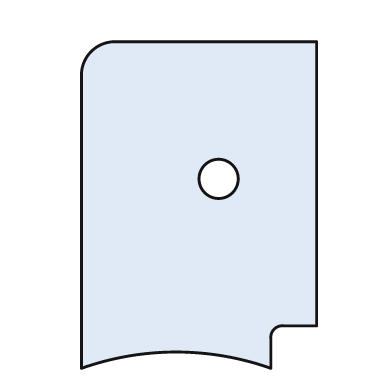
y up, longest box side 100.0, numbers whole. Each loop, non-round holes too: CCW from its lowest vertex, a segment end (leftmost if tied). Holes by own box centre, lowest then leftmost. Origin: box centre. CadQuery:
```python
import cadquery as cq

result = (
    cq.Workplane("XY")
    .moveTo(-36.0, -50.0)
    .threePointArc((-7.0, -45.0), (22.0, -50.0))
    .lineTo(22.0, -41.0)
    .threePointArc((23.0, -38.0), (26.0, -37.0))
    .lineTo(36.0, -37.0)
    .lineTo(36.0, 50.0)
    .lineTo(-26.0, 50.0)
    .threePointArc((-33.0, 47.0), (-36.0, 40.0))
    .close()
    .moveTo(6.0, 8.0)
    .circle(6.0)
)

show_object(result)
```